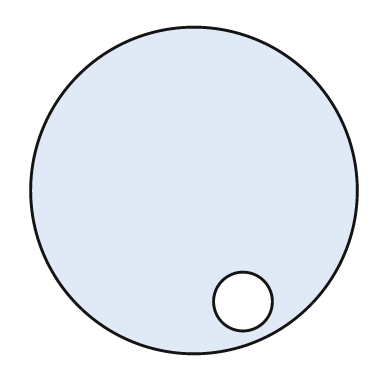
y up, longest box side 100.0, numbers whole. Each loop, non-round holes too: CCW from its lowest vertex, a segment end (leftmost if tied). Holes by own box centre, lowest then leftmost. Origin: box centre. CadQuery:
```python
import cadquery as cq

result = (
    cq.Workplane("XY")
    .moveTo(0.0, 0.0)
    .circle(50.0)
    .moveTo(15.0, -34.0)
    .circle(9.0)
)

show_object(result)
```